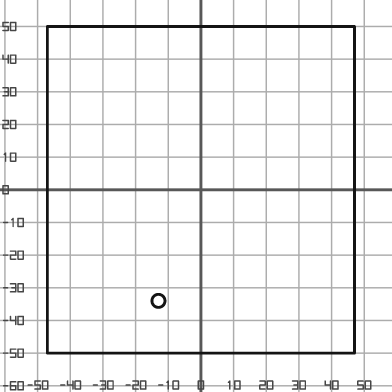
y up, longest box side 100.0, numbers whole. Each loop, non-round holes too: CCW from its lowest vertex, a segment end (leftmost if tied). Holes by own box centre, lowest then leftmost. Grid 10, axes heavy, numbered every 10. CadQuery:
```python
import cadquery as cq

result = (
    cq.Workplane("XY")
    .moveTo(-47.0, -50.0)
    .lineTo(47.0, -50.0)
    .lineTo(47.0, 50.0)
    .lineTo(-47.0, 50.0)
    .close()
    .moveTo(-13.0, -34.0)
    .circle(2.0)
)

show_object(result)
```